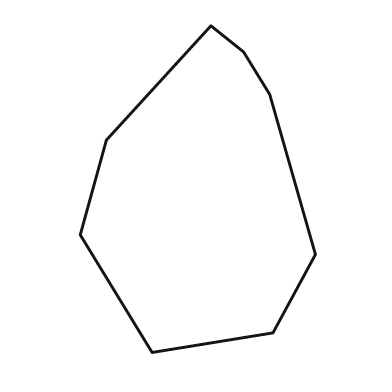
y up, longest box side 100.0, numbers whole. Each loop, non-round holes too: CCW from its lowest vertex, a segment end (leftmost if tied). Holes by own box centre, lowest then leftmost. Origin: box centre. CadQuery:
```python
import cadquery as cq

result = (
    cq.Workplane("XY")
    .moveTo(-14.0, -50.0)
    .lineTo(23.0, -44.0)
    .lineTo(36.0, -20.0)
    .lineTo(22.0, 29.0)
    .lineTo(14.0, 42.0)
    .lineTo(4.0, 50.0)
    .lineTo(-28.0, 15.0)
    .lineTo(-36.0, -14.0)
    .close()
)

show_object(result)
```